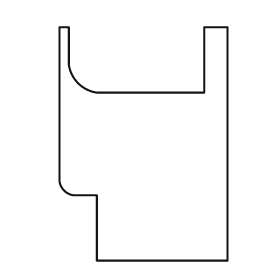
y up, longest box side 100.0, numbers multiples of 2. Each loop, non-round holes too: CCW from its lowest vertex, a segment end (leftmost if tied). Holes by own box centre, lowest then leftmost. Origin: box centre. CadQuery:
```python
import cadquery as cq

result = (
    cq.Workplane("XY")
    .moveTo(-20.0, -50.0)
    .lineTo(36.0, -50.0)
    .lineTo(36.0, 50.0)
    .lineTo(26.0, 50.0)
    .lineTo(26.0, 22.0)
    .lineTo(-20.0, 22.0)
    .threePointArc((-28.0, 26.0), (-32.0, 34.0))
    .lineTo(-32.0, 50.0)
    .lineTo(-36.0, 50.0)
    .lineTo(-36.0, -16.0)
    .threePointArc((-34.0, -20.0), (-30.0, -22.0))
    .lineTo(-20.0, -22.0)
    .close()
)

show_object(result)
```